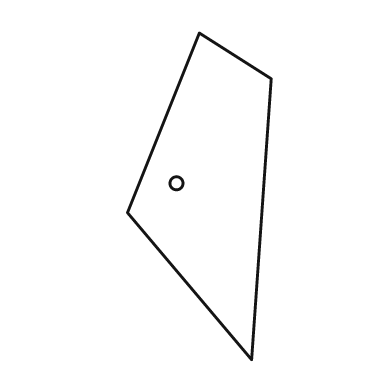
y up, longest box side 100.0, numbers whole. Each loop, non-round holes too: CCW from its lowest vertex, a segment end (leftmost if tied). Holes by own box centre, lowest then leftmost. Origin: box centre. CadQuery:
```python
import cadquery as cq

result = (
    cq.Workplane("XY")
    .moveTo(16.0, -50.0)
    .lineTo(22.0, 36.0)
    .lineTo(0.0, 50.0)
    .lineTo(-22.0, -5.0)
    .close()
    .moveTo(-7.0, 4.0)
    .circle(2.0)
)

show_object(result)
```